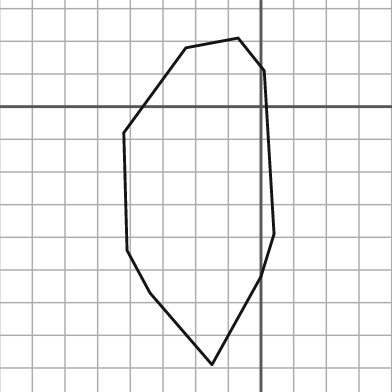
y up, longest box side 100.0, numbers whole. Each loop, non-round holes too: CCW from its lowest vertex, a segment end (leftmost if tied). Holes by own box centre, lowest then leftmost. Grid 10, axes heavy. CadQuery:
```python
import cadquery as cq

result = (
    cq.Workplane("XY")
    .moveTo(-15.0, -79.0)
    .lineTo(0.0, -52.0)
    .lineTo(4.0, -39.0)
    .lineTo(1.0, 11.0)
    .lineTo(-7.0, 21.0)
    .lineTo(-23.0, 18.0)
    .lineTo(-42.0, -8.0)
    .lineTo(-41.0, -44.0)
    .lineTo(-34.0, -57.0)
    .close()
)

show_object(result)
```